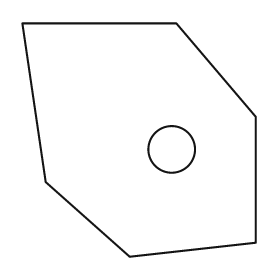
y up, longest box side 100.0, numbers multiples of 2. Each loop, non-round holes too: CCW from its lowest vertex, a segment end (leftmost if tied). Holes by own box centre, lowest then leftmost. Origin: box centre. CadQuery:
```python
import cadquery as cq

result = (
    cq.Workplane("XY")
    .moveTo(-4.0, -50.0)
    .lineTo(50.0, -44.0)
    .lineTo(50.0, 10.0)
    .lineTo(16.0, 50.0)
    .lineTo(-50.0, 50.0)
    .lineTo(-40.0, -18.0)
    .close()
    .moveTo(14.0, -4.0)
    .circle(10.0)
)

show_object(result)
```